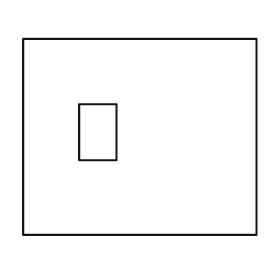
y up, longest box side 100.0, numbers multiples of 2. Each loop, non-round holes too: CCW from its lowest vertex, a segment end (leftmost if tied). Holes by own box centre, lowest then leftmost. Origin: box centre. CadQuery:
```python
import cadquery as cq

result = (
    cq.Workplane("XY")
    .moveTo(-50.0, -42.0)
    .lineTo(50.0, -42.0)
    .lineTo(50.0, 42.0)
    .lineTo(-50.0, 42.0)
    .close()
    .moveTo(-26.0, -10.0)
    .lineTo(-10.0, -10.0)
    .lineTo(-10.0, 14.0)
    .lineTo(-26.0, 14.0)
    .close()
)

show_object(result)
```